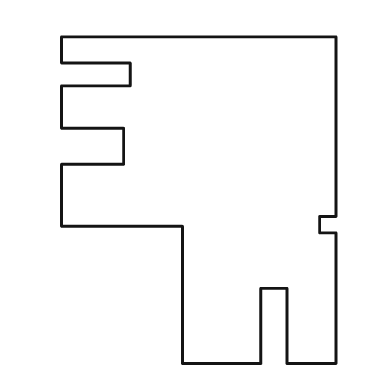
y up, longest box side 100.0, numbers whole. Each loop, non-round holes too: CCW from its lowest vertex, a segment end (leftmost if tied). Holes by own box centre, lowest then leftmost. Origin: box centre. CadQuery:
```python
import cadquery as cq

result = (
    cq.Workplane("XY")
    .moveTo(-5.0, -50.0)
    .lineTo(19.0, -50.0)
    .lineTo(19.0, -27.0)
    .lineTo(27.0, -27.0)
    .lineTo(27.0, -50.0)
    .lineTo(42.0, -50.0)
    .lineTo(42.0, -10.0)
    .lineTo(37.0, -10.0)
    .lineTo(37.0, -5.0)
    .lineTo(42.0, -5.0)
    .lineTo(42.0, 50.0)
    .lineTo(-42.0, 50.0)
    .lineTo(-42.0, 42.0)
    .lineTo(-21.0, 42.0)
    .lineTo(-21.0, 35.0)
    .lineTo(-42.0, 35.0)
    .lineTo(-42.0, 22.0)
    .lineTo(-23.0, 22.0)
    .lineTo(-23.0, 11.0)
    .lineTo(-42.0, 11.0)
    .lineTo(-42.0, -8.0)
    .lineTo(-5.0, -8.0)
    .close()
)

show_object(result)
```